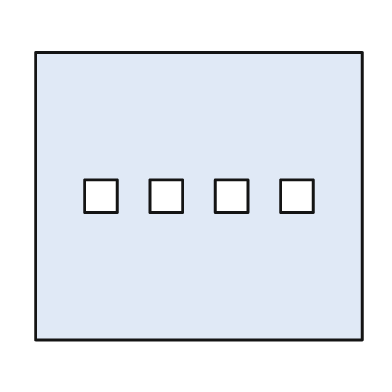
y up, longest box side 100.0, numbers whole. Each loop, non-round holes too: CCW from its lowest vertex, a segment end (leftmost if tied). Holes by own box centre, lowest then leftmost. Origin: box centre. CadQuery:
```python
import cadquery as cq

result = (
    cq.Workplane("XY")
    .moveTo(-50.0, -44.0)
    .lineTo(50.0, -44.0)
    .lineTo(50.0, 44.0)
    .lineTo(-50.0, 44.0)
    .close()
    .moveTo(-35.0, -5.0)
    .lineTo(-25.0, -5.0)
    .lineTo(-25.0, 5.0)
    .lineTo(-35.0, 5.0)
    .close()
    .moveTo(-15.0, -5.0)
    .lineTo(-5.0, -5.0)
    .lineTo(-5.0, 5.0)
    .lineTo(-15.0, 5.0)
    .close()
    .moveTo(5.0, -5.0)
    .lineTo(15.0, -5.0)
    .lineTo(15.0, 5.0)
    .lineTo(5.0, 5.0)
    .close()
    .moveTo(25.0, -5.0)
    .lineTo(35.0, -5.0)
    .lineTo(35.0, 5.0)
    .lineTo(25.0, 5.0)
    .close()
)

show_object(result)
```